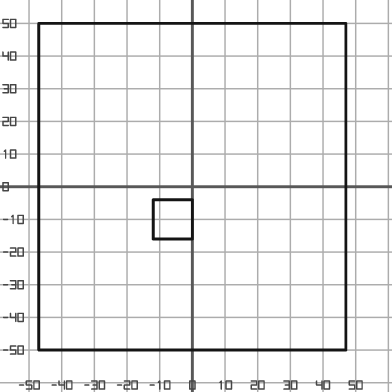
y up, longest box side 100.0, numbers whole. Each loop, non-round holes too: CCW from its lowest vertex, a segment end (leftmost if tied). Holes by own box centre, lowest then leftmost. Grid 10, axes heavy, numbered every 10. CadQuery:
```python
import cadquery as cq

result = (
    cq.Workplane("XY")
    .moveTo(-47.0, -50.0)
    .lineTo(47.0, -50.0)
    .lineTo(47.0, 50.0)
    .lineTo(-47.0, 50.0)
    .close()
    .moveTo(-12.0, -16.0)
    .lineTo(0.0, -16.0)
    .lineTo(0.0, -4.0)
    .lineTo(-12.0, -4.0)
    .close()
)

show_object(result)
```